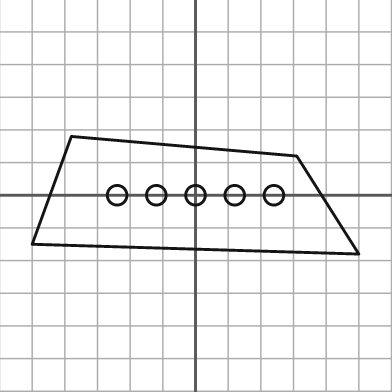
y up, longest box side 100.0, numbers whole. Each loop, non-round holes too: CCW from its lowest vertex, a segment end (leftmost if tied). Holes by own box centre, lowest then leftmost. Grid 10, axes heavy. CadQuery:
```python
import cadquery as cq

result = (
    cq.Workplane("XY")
    .moveTo(50.0, -18.0)
    .lineTo(31.0, 12.0)
    .lineTo(-38.0, 18.0)
    .lineTo(-50.0, -15.0)
    .close()
    .moveTo(-24.0, 0.0)
    .circle(3.0)
    .moveTo(-12.0, 0.0)
    .circle(3.0)
    .moveTo(0.0, 0.0)
    .circle(3.0)
    .moveTo(12.0, 0.0)
    .circle(3.0)
    .moveTo(24.0, 0.0)
    .circle(3.0)
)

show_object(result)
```